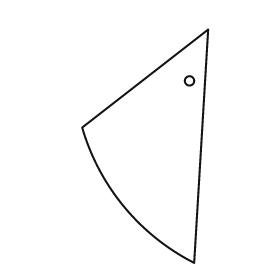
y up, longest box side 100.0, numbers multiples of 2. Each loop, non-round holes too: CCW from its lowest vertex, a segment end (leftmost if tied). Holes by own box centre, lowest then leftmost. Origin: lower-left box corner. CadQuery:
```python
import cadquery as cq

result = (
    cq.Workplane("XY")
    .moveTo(48.0, 0.0)
    .lineTo(54.0, 100.0)
    .lineTo(0.0, 58.0)
    .threePointArc((18.0, 24.0), (48.0, 0.0))
    .close()
    .moveTo(46.0, 78.0)
    .circle(2.0)
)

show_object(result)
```